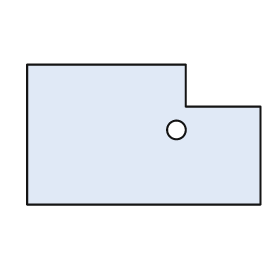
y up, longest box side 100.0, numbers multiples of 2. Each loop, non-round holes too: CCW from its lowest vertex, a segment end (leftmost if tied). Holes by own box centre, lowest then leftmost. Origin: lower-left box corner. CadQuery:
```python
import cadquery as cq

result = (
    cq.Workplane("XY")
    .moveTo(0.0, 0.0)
    .lineTo(100.0, 0.0)
    .lineTo(100.0, 42.0)
    .lineTo(68.0, 42.0)
    .lineTo(68.0, 60.0)
    .lineTo(0.0, 60.0)
    .close()
    .moveTo(64.0, 32.0)
    .circle(4.0)
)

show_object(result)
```